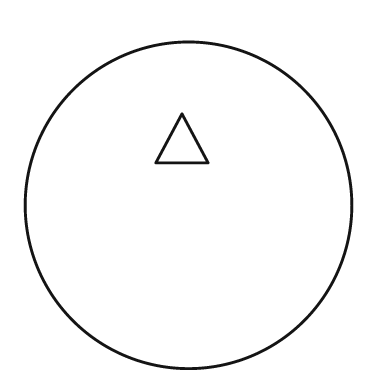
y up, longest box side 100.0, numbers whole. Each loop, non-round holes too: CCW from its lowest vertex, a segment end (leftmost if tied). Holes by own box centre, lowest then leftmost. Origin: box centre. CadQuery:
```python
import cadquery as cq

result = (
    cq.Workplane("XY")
    .moveTo(0.0, 0.0)
    .circle(50.0)
    .moveTo(-10.0, 13.0)
    .lineTo(6.0, 13.0)
    .lineTo(-2.0, 28.0)
    .close()
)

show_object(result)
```